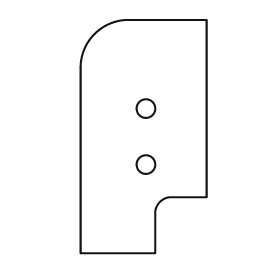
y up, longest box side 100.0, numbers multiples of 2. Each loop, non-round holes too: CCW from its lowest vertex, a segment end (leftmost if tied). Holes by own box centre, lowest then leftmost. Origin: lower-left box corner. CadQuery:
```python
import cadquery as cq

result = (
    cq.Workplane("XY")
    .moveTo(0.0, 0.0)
    .lineTo(32.0, 0.0)
    .lineTo(32.0, 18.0)
    .threePointArc((34.0, 22.0), (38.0, 24.0))
    .lineTo(54.0, 24.0)
    .lineTo(54.0, 100.0)
    .lineTo(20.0, 100.0)
    .threePointArc((6.0, 94.0), (0.0, 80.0))
    .close()
    .moveTo(28.0, 38.0)
    .circle(4.0)
    .moveTo(28.0, 62.0)
    .circle(4.0)
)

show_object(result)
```